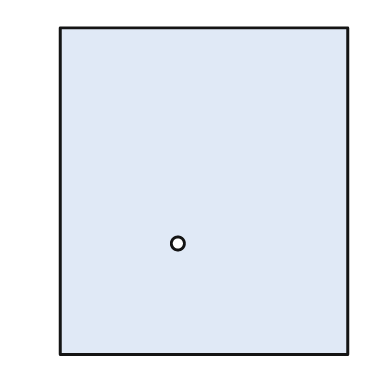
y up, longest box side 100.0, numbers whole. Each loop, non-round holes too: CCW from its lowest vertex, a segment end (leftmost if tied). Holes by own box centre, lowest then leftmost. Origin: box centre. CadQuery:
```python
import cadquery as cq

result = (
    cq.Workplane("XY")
    .moveTo(-44.0, -50.0)
    .lineTo(44.0, -50.0)
    .lineTo(44.0, 50.0)
    .lineTo(-44.0, 50.0)
    .close()
    .moveTo(-8.0, -16.0)
    .circle(2.0)
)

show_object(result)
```